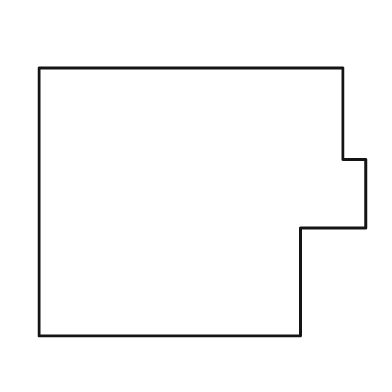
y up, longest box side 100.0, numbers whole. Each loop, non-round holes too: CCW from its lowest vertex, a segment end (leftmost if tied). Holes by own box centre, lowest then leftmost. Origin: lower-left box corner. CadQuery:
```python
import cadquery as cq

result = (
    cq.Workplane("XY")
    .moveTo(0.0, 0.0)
    .lineTo(80.0, 0.0)
    .lineTo(80.0, 33.0)
    .lineTo(100.0, 33.0)
    .lineTo(100.0, 54.0)
    .lineTo(93.0, 54.0)
    .lineTo(93.0, 82.0)
    .lineTo(0.0, 82.0)
    .close()
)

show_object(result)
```